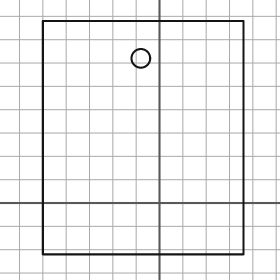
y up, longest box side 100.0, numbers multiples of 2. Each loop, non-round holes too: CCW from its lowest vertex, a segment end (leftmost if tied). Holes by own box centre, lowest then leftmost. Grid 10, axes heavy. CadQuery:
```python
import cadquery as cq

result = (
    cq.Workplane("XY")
    .moveTo(-50.0, -22.0)
    .lineTo(36.0, -22.0)
    .lineTo(36.0, 78.0)
    .lineTo(-50.0, 78.0)
    .close()
    .moveTo(-8.0, 62.0)
    .circle(4.0)
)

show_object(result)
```